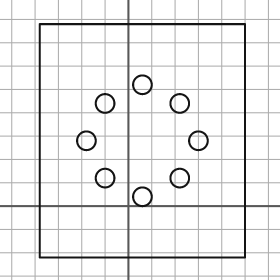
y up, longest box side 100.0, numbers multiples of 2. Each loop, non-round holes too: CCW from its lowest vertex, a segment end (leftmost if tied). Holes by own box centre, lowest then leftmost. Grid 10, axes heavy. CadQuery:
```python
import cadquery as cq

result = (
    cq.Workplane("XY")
    .moveTo(-38.0, -22.0)
    .lineTo(50.0, -22.0)
    .lineTo(50.0, 78.0)
    .lineTo(-38.0, 78.0)
    .close()
    .moveTo(6.0, 4.0)
    .circle(4.0)
    .moveTo(-10.0, 12.0)
    .circle(4.0)
    .moveTo(22.0, 12.0)
    .circle(4.0)
    .moveTo(-18.0, 28.0)
    .circle(4.0)
    .moveTo(30.0, 28.0)
    .circle(4.0)
    .moveTo(-10.0, 44.0)
    .circle(4.0)
    .moveTo(22.0, 44.0)
    .circle(4.0)
    .moveTo(6.0, 52.0)
    .circle(4.0)
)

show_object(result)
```